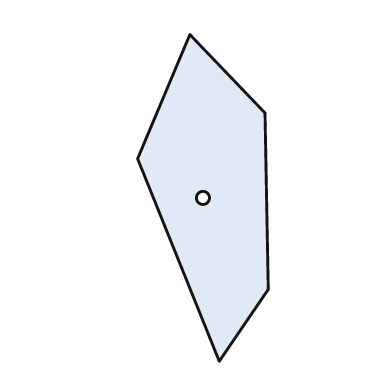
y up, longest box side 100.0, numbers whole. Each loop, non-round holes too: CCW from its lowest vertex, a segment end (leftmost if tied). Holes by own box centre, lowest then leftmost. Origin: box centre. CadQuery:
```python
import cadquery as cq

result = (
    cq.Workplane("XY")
    .moveTo(5.0, -50.0)
    .lineTo(20.0, -28.0)
    .lineTo(19.0, 26.0)
    .lineTo(-4.0, 50.0)
    .lineTo(-20.0, 12.0)
    .close()
    .moveTo(0.0, 0.0)
    .circle(2.0)
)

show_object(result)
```